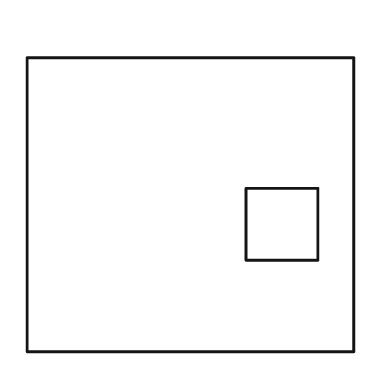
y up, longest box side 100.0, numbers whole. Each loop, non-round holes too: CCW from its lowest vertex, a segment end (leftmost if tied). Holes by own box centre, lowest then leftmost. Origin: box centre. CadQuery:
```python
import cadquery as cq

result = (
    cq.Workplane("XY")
    .moveTo(-50.0, -45.0)
    .lineTo(50.0, -45.0)
    .lineTo(50.0, 45.0)
    .lineTo(-50.0, 45.0)
    .close()
    .moveTo(17.0, -17.0)
    .lineTo(39.0, -17.0)
    .lineTo(39.0, 5.0)
    .lineTo(17.0, 5.0)
    .close()
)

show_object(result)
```